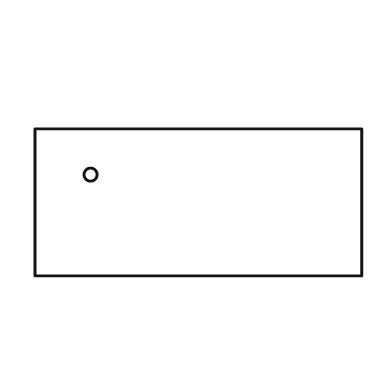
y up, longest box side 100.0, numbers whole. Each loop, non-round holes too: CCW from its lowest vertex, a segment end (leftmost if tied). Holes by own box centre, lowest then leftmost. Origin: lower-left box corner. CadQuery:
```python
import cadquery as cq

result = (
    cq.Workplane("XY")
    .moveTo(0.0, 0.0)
    .lineTo(100.0, 0.0)
    .lineTo(100.0, 45.0)
    .lineTo(0.0, 45.0)
    .close()
    .moveTo(17.0, 31.0)
    .circle(2.0)
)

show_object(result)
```